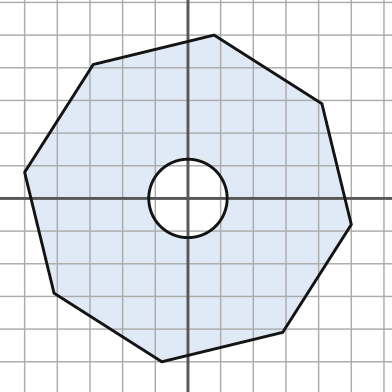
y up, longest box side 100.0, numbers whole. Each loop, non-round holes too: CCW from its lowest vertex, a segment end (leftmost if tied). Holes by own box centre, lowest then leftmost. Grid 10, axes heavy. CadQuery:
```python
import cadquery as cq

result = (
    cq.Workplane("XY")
    .moveTo(-8.0, -50.0)
    .lineTo(29.0, -41.0)
    .lineTo(50.0, -8.0)
    .lineTo(41.0, 29.0)
    .lineTo(8.0, 50.0)
    .lineTo(-29.0, 41.0)
    .lineTo(-50.0, 8.0)
    .lineTo(-41.0, -29.0)
    .close()
    .moveTo(0.0, 0.0)
    .circle(12.0)
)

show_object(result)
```